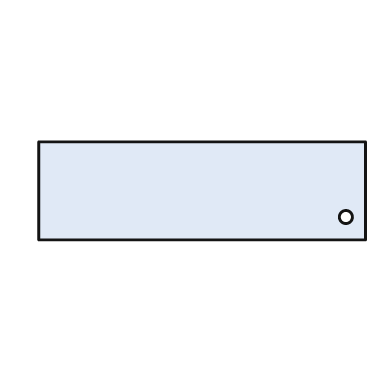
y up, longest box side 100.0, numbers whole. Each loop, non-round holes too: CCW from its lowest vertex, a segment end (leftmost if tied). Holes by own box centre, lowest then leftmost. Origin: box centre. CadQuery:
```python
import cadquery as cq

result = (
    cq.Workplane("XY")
    .moveTo(-50.0, -15.0)
    .lineTo(50.0, -15.0)
    .lineTo(50.0, 15.0)
    .lineTo(-50.0, 15.0)
    .close()
    .moveTo(44.0, -8.0)
    .circle(2.0)
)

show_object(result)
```